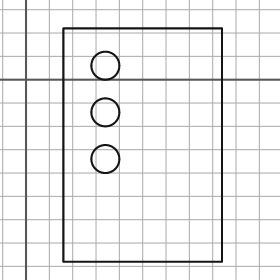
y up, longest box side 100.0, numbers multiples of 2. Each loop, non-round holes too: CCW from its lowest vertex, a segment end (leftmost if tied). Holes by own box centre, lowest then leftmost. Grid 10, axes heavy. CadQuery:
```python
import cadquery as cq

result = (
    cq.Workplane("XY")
    .moveTo(16.0, -78.0)
    .lineTo(84.0, -78.0)
    .lineTo(84.0, 22.0)
    .lineTo(16.0, 22.0)
    .close()
    .moveTo(34.0, -34.0)
    .circle(6.0)
    .moveTo(34.0, -14.0)
    .circle(6.0)
    .moveTo(34.0, 6.0)
    .circle(6.0)
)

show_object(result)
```